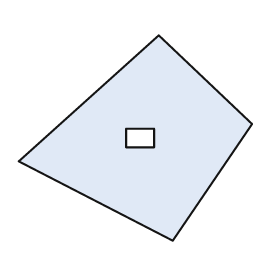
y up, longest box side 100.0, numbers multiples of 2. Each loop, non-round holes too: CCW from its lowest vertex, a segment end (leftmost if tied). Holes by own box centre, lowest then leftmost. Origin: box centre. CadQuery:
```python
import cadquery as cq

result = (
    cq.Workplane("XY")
    .moveTo(16.0, -44.0)
    .lineTo(50.0, 6.0)
    .lineTo(10.0, 44.0)
    .lineTo(-50.0, -10.0)
    .close()
    .moveTo(-4.0, -4.0)
    .lineTo(8.0, -4.0)
    .lineTo(8.0, 4.0)
    .lineTo(-4.0, 4.0)
    .close()
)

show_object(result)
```